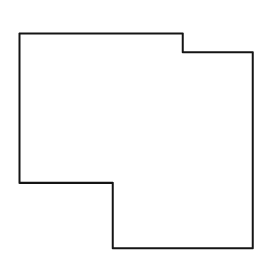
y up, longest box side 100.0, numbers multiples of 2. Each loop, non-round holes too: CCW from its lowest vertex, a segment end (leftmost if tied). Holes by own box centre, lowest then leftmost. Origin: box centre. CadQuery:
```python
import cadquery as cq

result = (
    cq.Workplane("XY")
    .moveTo(-10.0, -46.0)
    .lineTo(50.0, -46.0)
    .lineTo(50.0, 38.0)
    .lineTo(20.0, 38.0)
    .lineTo(20.0, 46.0)
    .lineTo(-50.0, 46.0)
    .lineTo(-50.0, -18.0)
    .lineTo(-10.0, -18.0)
    .close()
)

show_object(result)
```